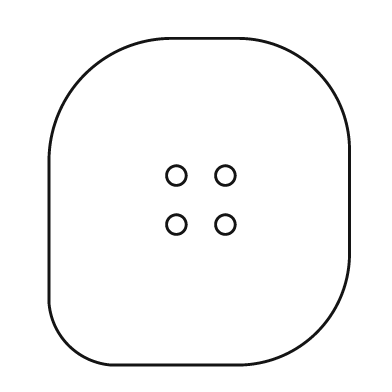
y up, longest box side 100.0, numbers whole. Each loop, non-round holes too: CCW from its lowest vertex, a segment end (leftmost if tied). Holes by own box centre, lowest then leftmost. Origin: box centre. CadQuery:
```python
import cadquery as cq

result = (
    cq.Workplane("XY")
    .moveTo(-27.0, -50.0)
    .lineTo(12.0, -50.0)
    .threePointArc((36.0, -40.0), (46.0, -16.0))
    .lineTo(46.0, 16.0)
    .threePointArc((36.0, 40.0), (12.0, 50.0))
    .lineTo(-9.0, 50.0)
    .threePointArc((-35.0, 39.0), (-46.0, 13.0))
    .lineTo(-46.0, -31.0)
    .threePointArc((-40.0, -44.0), (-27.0, -50.0))
    .close()
    .moveTo(-7.0, -7.0)
    .circle(3.0)
    .moveTo(8.0, -7.0)
    .circle(3.0)
    .moveTo(-7.0, 8.0)
    .circle(3.0)
    .moveTo(8.0, 8.0)
    .circle(3.0)
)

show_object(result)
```